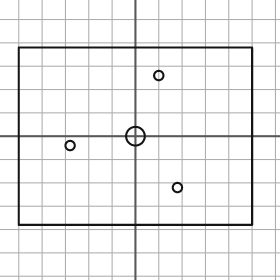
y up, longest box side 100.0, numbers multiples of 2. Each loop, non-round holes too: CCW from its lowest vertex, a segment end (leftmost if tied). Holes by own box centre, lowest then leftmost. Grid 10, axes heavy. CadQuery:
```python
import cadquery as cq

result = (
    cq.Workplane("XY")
    .moveTo(-50.0, -38.0)
    .lineTo(50.0, -38.0)
    .lineTo(50.0, 38.0)
    .lineTo(-50.0, 38.0)
    .close()
    .moveTo(18.0, -22.0)
    .circle(2.0)
    .moveTo(-28.0, -4.0)
    .circle(2.0)
    .moveTo(0.0, 0.0)
    .circle(4.0)
    .moveTo(10.0, 26.0)
    .circle(2.0)
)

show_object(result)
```